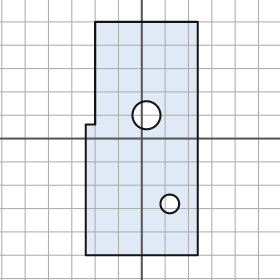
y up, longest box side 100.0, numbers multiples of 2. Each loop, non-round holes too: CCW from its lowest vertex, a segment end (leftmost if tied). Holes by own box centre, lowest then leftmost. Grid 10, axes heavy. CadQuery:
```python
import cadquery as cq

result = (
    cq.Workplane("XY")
    .moveTo(-24.0, -50.0)
    .lineTo(24.0, -50.0)
    .lineTo(24.0, 50.0)
    .lineTo(-20.0, 50.0)
    .lineTo(-20.0, 6.0)
    .lineTo(-24.0, 6.0)
    .close()
    .moveTo(12.0, -28.0)
    .circle(4.0)
    .moveTo(2.0, 10.0)
    .circle(6.0)
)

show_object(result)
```